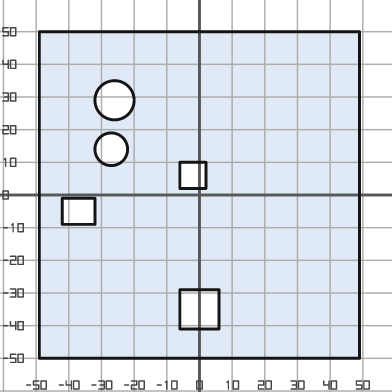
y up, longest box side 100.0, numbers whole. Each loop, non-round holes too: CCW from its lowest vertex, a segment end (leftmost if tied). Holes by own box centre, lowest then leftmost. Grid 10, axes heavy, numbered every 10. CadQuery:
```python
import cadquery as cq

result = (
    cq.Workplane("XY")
    .moveTo(-49.0, -50.0)
    .lineTo(49.0, -50.0)
    .lineTo(49.0, 50.0)
    .lineTo(-49.0, 50.0)
    .close()
    .moveTo(-6.0, -41.0)
    .lineTo(6.0, -41.0)
    .lineTo(6.0, -29.0)
    .lineTo(-6.0, -29.0)
    .close()
    .moveTo(-42.0, -9.0)
    .lineTo(-32.0, -9.0)
    .lineTo(-32.0, -1.0)
    .lineTo(-42.0, -1.0)
    .close()
    .moveTo(-6.0, 2.0)
    .lineTo(2.0, 2.0)
    .lineTo(2.0, 10.0)
    .lineTo(-6.0, 10.0)
    .close()
    .moveTo(-27.0, 14.0)
    .circle(5.0)
    .moveTo(-26.0, 29.0)
    .circle(6.0)
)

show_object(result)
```